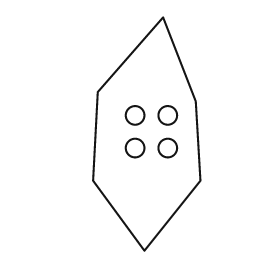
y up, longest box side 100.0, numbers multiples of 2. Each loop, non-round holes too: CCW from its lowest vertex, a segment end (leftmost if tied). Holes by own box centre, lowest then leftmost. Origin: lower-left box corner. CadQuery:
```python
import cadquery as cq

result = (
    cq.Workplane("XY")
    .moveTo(22.0, 0.0)
    .lineTo(46.0, 30.0)
    .lineTo(44.0, 64.0)
    .lineTo(30.0, 100.0)
    .lineTo(2.0, 68.0)
    .lineTo(0.0, 30.0)
    .close()
    .moveTo(18.0, 44.0)
    .circle(4.0)
    .moveTo(32.0, 44.0)
    .circle(4.0)
    .moveTo(18.0, 58.0)
    .circle(4.0)
    .moveTo(32.0, 58.0)
    .circle(4.0)
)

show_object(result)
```